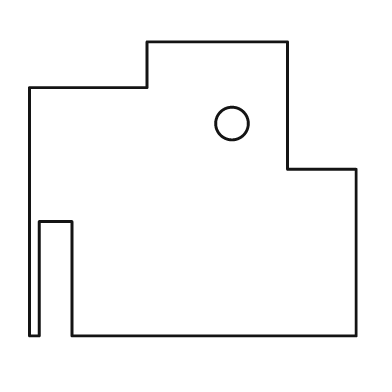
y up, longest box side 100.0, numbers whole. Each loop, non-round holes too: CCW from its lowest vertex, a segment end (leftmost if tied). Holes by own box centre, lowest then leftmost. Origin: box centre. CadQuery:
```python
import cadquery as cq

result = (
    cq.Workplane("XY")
    .moveTo(-50.0, -45.0)
    .lineTo(-47.0, -45.0)
    .lineTo(-47.0, -10.0)
    .lineTo(-37.0, -10.0)
    .lineTo(-37.0, -45.0)
    .lineTo(50.0, -45.0)
    .lineTo(50.0, 6.0)
    .lineTo(29.0, 6.0)
    .lineTo(29.0, 45.0)
    .lineTo(-14.0, 45.0)
    .lineTo(-14.0, 31.0)
    .lineTo(-50.0, 31.0)
    .close()
    .moveTo(12.0, 20.0)
    .circle(5.0)
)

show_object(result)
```